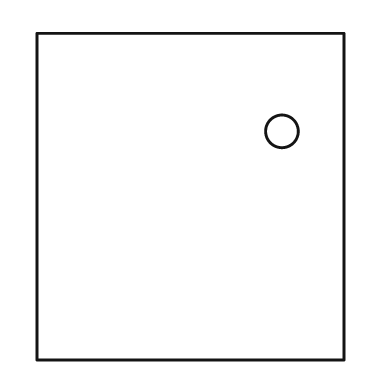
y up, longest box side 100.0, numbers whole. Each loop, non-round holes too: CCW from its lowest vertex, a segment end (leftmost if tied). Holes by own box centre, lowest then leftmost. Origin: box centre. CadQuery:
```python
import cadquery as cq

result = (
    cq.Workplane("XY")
    .moveTo(-47.0, -50.0)
    .lineTo(47.0, -50.0)
    .lineTo(47.0, 50.0)
    .lineTo(-47.0, 50.0)
    .close()
    .moveTo(28.0, 20.0)
    .circle(5.0)
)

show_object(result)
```